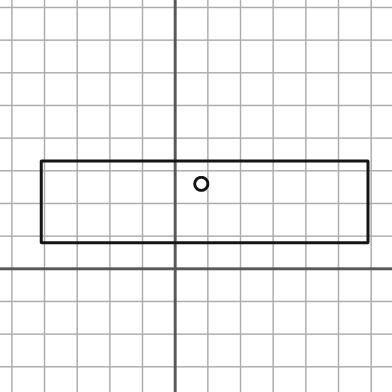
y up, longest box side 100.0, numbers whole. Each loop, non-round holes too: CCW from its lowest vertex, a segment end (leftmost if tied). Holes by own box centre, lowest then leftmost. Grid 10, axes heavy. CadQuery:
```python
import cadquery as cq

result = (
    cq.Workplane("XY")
    .moveTo(-41.0, 8.0)
    .lineTo(59.0, 8.0)
    .lineTo(59.0, 33.0)
    .lineTo(-41.0, 33.0)
    .close()
    .moveTo(8.0, 26.0)
    .circle(2.0)
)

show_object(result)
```